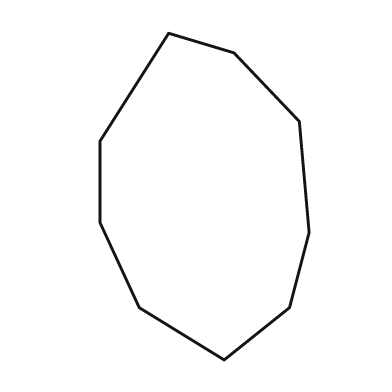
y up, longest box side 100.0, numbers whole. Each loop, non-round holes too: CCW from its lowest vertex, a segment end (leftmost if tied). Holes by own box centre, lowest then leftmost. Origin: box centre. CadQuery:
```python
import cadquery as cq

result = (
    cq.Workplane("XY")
    .moveTo(6.0, -50.0)
    .lineTo(26.0, -34.0)
    .lineTo(32.0, -11.0)
    .lineTo(29.0, 23.0)
    .lineTo(9.0, 44.0)
    .lineTo(-11.0, 50.0)
    .lineTo(-32.0, 17.0)
    .lineTo(-32.0, -8.0)
    .lineTo(-20.0, -34.0)
    .close()
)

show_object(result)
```